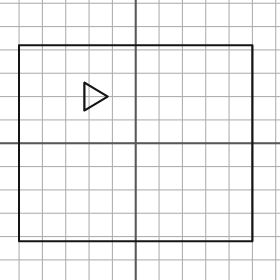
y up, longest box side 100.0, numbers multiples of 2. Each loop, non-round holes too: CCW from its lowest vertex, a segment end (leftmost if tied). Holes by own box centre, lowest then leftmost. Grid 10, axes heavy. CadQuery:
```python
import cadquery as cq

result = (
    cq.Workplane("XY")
    .moveTo(-50.0, -42.0)
    .lineTo(50.0, -42.0)
    .lineTo(50.0, 42.0)
    .lineTo(-50.0, 42.0)
    .close()
    .moveTo(-22.0, 14.0)
    .lineTo(-12.0, 20.0)
    .lineTo(-22.0, 26.0)
    .close()
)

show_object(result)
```